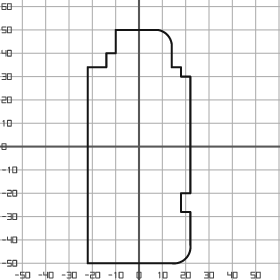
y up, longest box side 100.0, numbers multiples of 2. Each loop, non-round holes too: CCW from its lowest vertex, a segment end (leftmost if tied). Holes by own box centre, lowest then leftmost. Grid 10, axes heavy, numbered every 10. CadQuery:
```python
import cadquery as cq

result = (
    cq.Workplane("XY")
    .moveTo(-22.0, -50.0)
    .lineTo(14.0, -50.0)
    .threePointArc((20.0, -48.0), (22.0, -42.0))
    .lineTo(22.0, -28.0)
    .lineTo(18.0, -28.0)
    .lineTo(18.0, -20.0)
    .lineTo(22.0, -20.0)
    .lineTo(22.0, 30.0)
    .lineTo(18.0, 30.0)
    .lineTo(18.0, 34.0)
    .lineTo(14.0, 34.0)
    .lineTo(14.0, 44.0)
    .threePointArc((12.0, 48.0), (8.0, 50.0))
    .lineTo(-10.0, 50.0)
    .lineTo(-10.0, 40.0)
    .lineTo(-14.0, 40.0)
    .lineTo(-14.0, 34.0)
    .lineTo(-22.0, 34.0)
    .close()
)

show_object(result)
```